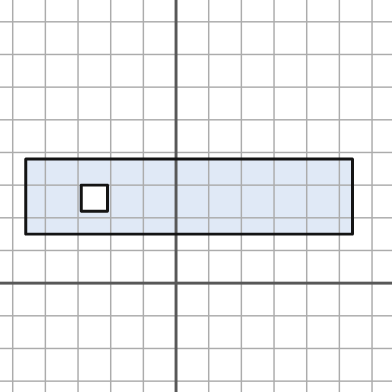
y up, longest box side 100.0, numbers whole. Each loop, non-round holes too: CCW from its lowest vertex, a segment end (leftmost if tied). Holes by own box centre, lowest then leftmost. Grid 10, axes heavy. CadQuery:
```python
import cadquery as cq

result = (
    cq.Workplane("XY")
    .moveTo(-46.0, 15.0)
    .lineTo(54.0, 15.0)
    .lineTo(54.0, 38.0)
    .lineTo(-46.0, 38.0)
    .close()
    .moveTo(-29.0, 22.0)
    .lineTo(-21.0, 22.0)
    .lineTo(-21.0, 30.0)
    .lineTo(-29.0, 30.0)
    .close()
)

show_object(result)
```